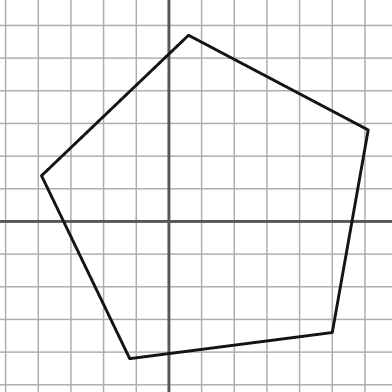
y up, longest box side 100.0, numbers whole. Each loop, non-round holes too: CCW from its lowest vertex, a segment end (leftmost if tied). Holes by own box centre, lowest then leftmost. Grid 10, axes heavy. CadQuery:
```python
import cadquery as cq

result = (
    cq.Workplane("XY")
    .moveTo(-12.0, -42.0)
    .lineTo(50.0, -34.0)
    .lineTo(61.0, 28.0)
    .lineTo(6.0, 57.0)
    .lineTo(-39.0, 14.0)
    .close()
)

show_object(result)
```